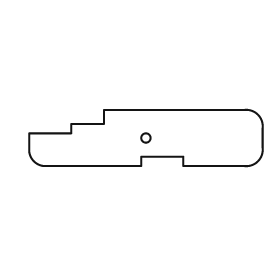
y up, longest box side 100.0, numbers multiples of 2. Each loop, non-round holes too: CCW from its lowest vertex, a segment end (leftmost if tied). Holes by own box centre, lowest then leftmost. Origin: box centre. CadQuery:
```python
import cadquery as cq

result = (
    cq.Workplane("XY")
    .moveTo(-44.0, -12.0)
    .lineTo(-2.0, -12.0)
    .lineTo(-2.0, -8.0)
    .lineTo(16.0, -8.0)
    .lineTo(16.0, -12.0)
    .lineTo(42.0, -12.0)
    .threePointArc((48.0, -10.0), (50.0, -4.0))
    .lineTo(50.0, 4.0)
    .threePointArc((48.0, 10.0), (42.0, 12.0))
    .lineTo(-18.0, 12.0)
    .lineTo(-18.0, 6.0)
    .lineTo(-32.0, 6.0)
    .lineTo(-32.0, 2.0)
    .lineTo(-50.0, 2.0)
    .lineTo(-50.0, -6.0)
    .threePointArc((-48.0, -10.0), (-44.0, -12.0))
    .close()
    .moveTo(0.0, 0.0)
    .circle(2.0)
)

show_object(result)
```